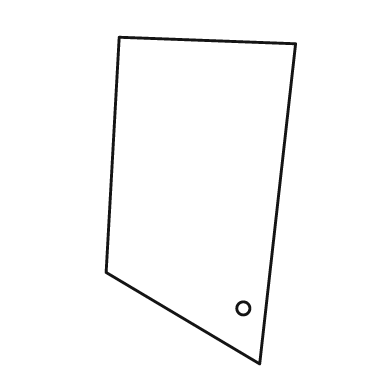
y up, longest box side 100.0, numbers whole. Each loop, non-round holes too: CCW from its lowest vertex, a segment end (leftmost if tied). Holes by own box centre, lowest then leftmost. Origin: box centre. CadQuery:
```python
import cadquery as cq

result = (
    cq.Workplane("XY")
    .moveTo(18.0, -50.0)
    .lineTo(29.0, 48.0)
    .lineTo(-25.0, 50.0)
    .lineTo(-29.0, -22.0)
    .close()
    .moveTo(13.0, -33.0)
    .circle(2.0)
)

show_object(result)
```